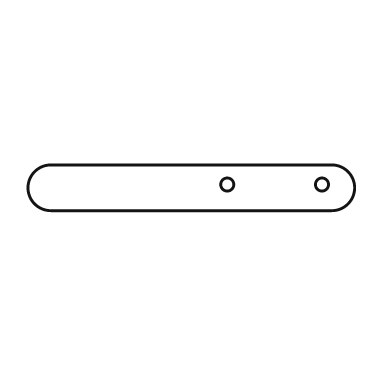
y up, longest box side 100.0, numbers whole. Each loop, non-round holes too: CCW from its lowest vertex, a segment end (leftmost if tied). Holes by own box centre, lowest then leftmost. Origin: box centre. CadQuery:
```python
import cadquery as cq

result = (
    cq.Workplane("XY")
    .moveTo(-43.0, -7.0)
    .lineTo(43.0, -7.0)
    .threePointArc((50.0, 0.0), (43.0, 7.0))
    .lineTo(-43.0, 7.0)
    .threePointArc((-50.0, 0.0), (-43.0, -7.0))
    .close()
    .moveTo(11.0, 1.0)
    .circle(2.0)
    .moveTo(40.0, 1.0)
    .circle(2.0)
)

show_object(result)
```